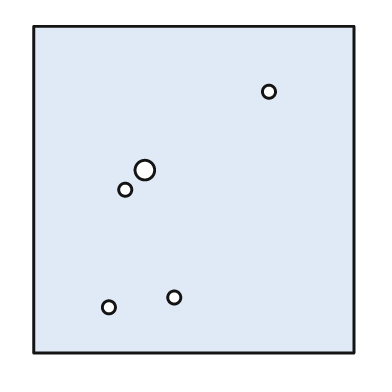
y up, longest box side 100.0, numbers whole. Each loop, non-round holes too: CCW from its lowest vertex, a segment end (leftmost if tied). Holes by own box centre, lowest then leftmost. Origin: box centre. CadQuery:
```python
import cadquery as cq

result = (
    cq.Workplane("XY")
    .moveTo(-49.0, -50.0)
    .lineTo(49.0, -50.0)
    .lineTo(49.0, 50.0)
    .lineTo(-49.0, 50.0)
    .close()
    .moveTo(-26.0, -36.0)
    .circle(2.0)
    .moveTo(-6.0, -33.0)
    .circle(2.0)
    .moveTo(-21.0, 0.0)
    .circle(2.0)
    .moveTo(-15.0, 6.0)
    .circle(3.0)
    .moveTo(23.0, 30.0)
    .circle(2.0)
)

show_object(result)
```